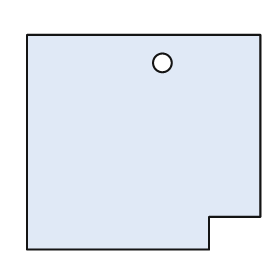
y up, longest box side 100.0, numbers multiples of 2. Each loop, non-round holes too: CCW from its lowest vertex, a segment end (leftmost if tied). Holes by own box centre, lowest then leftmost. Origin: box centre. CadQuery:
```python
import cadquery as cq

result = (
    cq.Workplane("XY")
    .moveTo(-50.0, -46.0)
    .lineTo(28.0, -46.0)
    .lineTo(28.0, -32.0)
    .lineTo(50.0, -32.0)
    .lineTo(50.0, 46.0)
    .lineTo(-50.0, 46.0)
    .close()
    .moveTo(8.0, 34.0)
    .circle(4.0)
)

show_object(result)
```